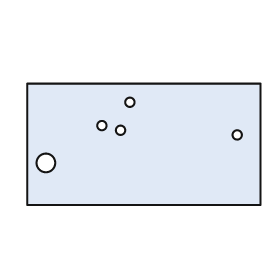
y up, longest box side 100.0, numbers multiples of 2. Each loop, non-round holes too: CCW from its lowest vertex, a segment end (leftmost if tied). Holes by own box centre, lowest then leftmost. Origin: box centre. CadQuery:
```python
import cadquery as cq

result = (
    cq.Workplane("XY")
    .moveTo(-50.0, -26.0)
    .lineTo(50.0, -26.0)
    .lineTo(50.0, 26.0)
    .lineTo(-50.0, 26.0)
    .close()
    .moveTo(-42.0, -8.0)
    .circle(4.0)
    .moveTo(40.0, 4.0)
    .circle(2.0)
    .moveTo(-10.0, 6.0)
    .circle(2.0)
    .moveTo(-18.0, 8.0)
    .circle(2.0)
    .moveTo(-6.0, 18.0)
    .circle(2.0)
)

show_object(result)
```